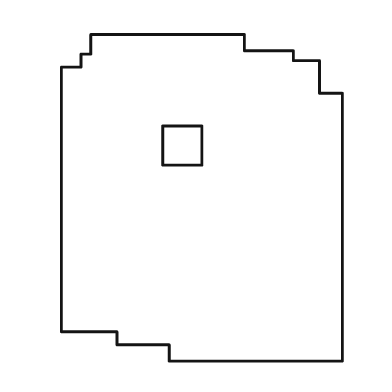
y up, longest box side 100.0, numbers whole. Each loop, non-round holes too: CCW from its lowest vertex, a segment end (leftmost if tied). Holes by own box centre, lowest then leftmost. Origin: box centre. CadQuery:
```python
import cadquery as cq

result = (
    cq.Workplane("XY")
    .moveTo(-10.0, -50.0)
    .lineTo(43.0, -50.0)
    .lineTo(43.0, 32.0)
    .lineTo(36.0, 32.0)
    .lineTo(36.0, 42.0)
    .lineTo(28.0, 42.0)
    .lineTo(28.0, 45.0)
    .lineTo(13.0, 45.0)
    .lineTo(13.0, 50.0)
    .lineTo(-34.0, 50.0)
    .lineTo(-34.0, 44.0)
    .lineTo(-37.0, 44.0)
    .lineTo(-37.0, 40.0)
    .lineTo(-43.0, 40.0)
    .lineTo(-43.0, -41.0)
    .lineTo(-26.0, -41.0)
    .lineTo(-26.0, -45.0)
    .lineTo(-10.0, -45.0)
    .close()
    .moveTo(-12.0, 10.0)
    .lineTo(0.0, 10.0)
    .lineTo(0.0, 22.0)
    .lineTo(-12.0, 22.0)
    .close()
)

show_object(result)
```